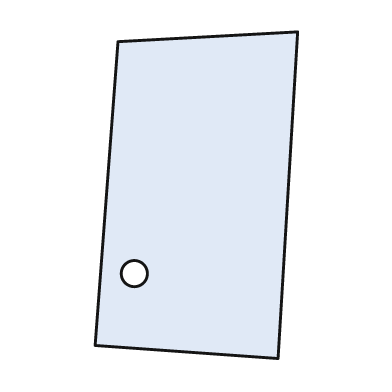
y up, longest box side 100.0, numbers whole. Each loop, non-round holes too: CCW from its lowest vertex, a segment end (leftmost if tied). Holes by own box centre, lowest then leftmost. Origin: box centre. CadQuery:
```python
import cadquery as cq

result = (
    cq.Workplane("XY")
    .moveTo(25.0, -50.0)
    .lineTo(31.0, 50.0)
    .lineTo(-24.0, 47.0)
    .lineTo(-31.0, -46.0)
    .close()
    .moveTo(-19.0, -24.0)
    .circle(4.0)
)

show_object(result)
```